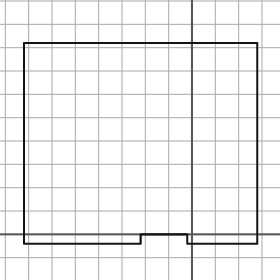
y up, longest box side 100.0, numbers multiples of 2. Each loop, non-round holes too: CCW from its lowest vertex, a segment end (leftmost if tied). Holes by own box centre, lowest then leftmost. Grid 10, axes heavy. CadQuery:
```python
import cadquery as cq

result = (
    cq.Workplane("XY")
    .moveTo(-72.0, -4.0)
    .lineTo(-22.0, -4.0)
    .lineTo(-22.0, 0.0)
    .lineTo(-2.0, 0.0)
    .lineTo(-2.0, -4.0)
    .lineTo(28.0, -4.0)
    .lineTo(28.0, 82.0)
    .lineTo(-72.0, 82.0)
    .close()
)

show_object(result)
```